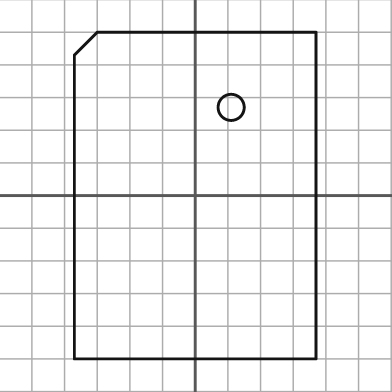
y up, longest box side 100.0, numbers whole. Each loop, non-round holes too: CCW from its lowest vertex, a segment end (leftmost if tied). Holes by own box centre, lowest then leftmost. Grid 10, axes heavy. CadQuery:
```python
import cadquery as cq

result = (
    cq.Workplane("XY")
    .moveTo(-37.0, -50.0)
    .lineTo(37.0, -50.0)
    .lineTo(37.0, 50.0)
    .lineTo(-30.0, 50.0)
    .lineTo(-37.0, 43.0)
    .close()
    .moveTo(11.0, 27.0)
    .circle(4.0)
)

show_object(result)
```